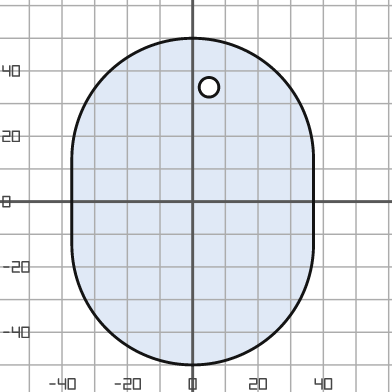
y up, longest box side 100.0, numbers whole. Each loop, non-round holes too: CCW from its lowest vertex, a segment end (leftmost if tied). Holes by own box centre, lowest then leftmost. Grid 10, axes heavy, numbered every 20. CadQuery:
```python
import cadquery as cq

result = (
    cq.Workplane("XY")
    .moveTo(-37.0, -13.0)
    .threePointArc((0.0, -50.0), (37.0, -13.0))
    .lineTo(37.0, 13.0)
    .threePointArc((0.0, 50.0), (-37.0, 13.0))
    .close()
    .moveTo(5.0, 35.0)
    .circle(3.0)
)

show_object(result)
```